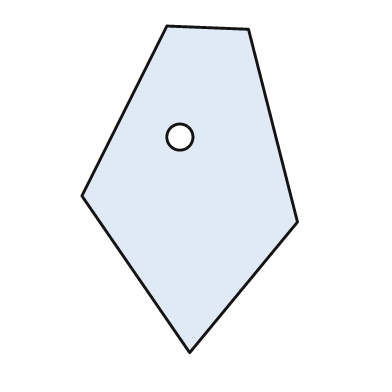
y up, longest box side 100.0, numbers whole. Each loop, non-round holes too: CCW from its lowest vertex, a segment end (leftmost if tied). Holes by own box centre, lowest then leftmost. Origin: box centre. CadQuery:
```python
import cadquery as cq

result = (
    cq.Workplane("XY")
    .moveTo(0.0, -50.0)
    .lineTo(33.0, -10.0)
    .lineTo(18.0, 49.0)
    .lineTo(-7.0, 50.0)
    .lineTo(-33.0, -2.0)
    .close()
    .moveTo(-3.0, 16.0)
    .circle(4.0)
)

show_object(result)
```